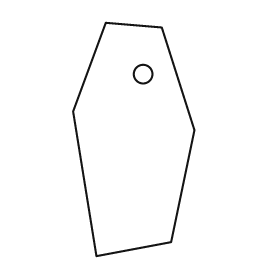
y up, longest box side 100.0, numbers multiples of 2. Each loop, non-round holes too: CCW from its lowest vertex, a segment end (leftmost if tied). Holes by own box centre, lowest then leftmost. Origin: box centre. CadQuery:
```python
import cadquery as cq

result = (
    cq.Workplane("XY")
    .moveTo(-16.0, -50.0)
    .lineTo(16.0, -44.0)
    .lineTo(26.0, 4.0)
    .lineTo(12.0, 48.0)
    .lineTo(-12.0, 50.0)
    .lineTo(-26.0, 12.0)
    .close()
    .moveTo(4.0, 28.0)
    .circle(4.0)
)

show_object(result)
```